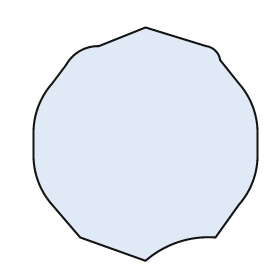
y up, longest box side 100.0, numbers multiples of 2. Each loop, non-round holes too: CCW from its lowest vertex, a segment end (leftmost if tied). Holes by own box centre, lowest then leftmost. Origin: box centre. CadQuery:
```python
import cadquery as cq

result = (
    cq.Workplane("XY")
    .moveTo(0.0, -50.0)
    .threePointArc((14.0, -42.0), (30.0, -40.0))
    .lineTo(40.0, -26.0)
    .threePointArc((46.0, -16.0), (48.0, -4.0))
    .lineTo(48.0, 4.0)
    .threePointArc((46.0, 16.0), (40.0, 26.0))
    .lineTo(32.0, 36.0)
    .threePointArc((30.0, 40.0), (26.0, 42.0))
    .lineTo(0.0, 50.0)
    .lineTo(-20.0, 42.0)
    .threePointArc((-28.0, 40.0), (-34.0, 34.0))
    .lineTo(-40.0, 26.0)
    .threePointArc((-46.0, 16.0), (-48.0, 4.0))
    .lineTo(-48.0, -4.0)
    .threePointArc((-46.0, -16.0), (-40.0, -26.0))
    .lineTo(-28.0, -40.0)
    .close()
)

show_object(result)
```